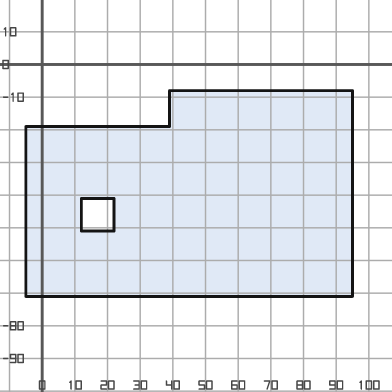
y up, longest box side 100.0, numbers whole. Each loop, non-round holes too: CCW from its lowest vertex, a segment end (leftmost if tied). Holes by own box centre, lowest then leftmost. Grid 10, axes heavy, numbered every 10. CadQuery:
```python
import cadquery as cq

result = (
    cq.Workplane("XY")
    .moveTo(-5.0, -71.0)
    .lineTo(95.0, -71.0)
    .lineTo(95.0, -8.0)
    .lineTo(39.0, -8.0)
    .lineTo(39.0, -19.0)
    .lineTo(-5.0, -19.0)
    .close()
    .moveTo(12.0, -51.0)
    .lineTo(22.0, -51.0)
    .lineTo(22.0, -41.0)
    .lineTo(12.0, -41.0)
    .close()
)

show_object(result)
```